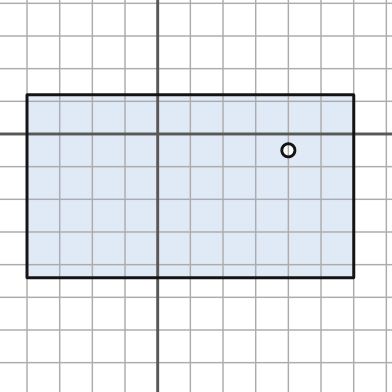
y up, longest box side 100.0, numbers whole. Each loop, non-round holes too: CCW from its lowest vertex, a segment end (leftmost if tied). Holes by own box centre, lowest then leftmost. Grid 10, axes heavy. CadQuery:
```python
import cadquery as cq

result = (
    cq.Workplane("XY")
    .moveTo(-40.0, -44.0)
    .lineTo(60.0, -44.0)
    .lineTo(60.0, 12.0)
    .lineTo(-40.0, 12.0)
    .close()
    .moveTo(40.0, -5.0)
    .circle(2.0)
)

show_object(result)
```